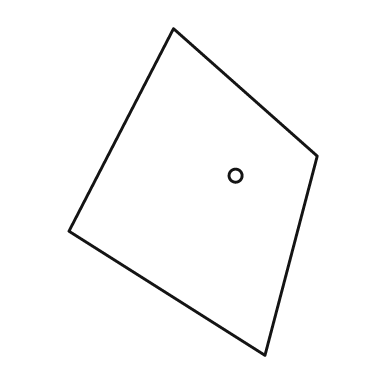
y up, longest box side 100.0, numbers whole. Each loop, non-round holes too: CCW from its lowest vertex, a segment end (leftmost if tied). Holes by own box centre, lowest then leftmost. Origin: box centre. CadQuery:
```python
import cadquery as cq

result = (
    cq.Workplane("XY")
    .moveTo(22.0, -50.0)
    .lineTo(38.0, 11.0)
    .lineTo(-6.0, 50.0)
    .lineTo(-38.0, -12.0)
    .close()
    .moveTo(13.0, 5.0)
    .circle(2.0)
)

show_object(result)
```